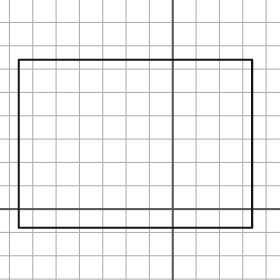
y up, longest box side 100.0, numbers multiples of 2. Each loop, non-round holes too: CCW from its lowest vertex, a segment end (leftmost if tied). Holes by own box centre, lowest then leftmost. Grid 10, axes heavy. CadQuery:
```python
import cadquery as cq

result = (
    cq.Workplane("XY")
    .moveTo(-66.0, -8.0)
    .lineTo(34.0, -8.0)
    .lineTo(34.0, 64.0)
    .lineTo(-66.0, 64.0)
    .close()
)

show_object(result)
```